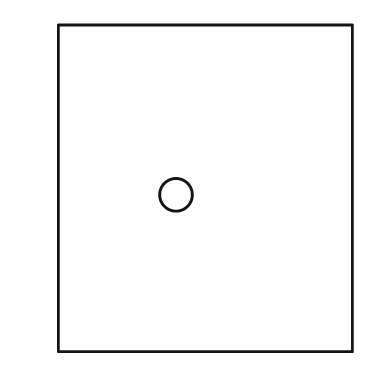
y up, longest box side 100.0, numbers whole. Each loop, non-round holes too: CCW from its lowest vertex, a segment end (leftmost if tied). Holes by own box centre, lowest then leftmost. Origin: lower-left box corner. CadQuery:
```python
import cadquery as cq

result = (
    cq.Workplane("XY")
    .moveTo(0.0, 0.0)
    .lineTo(90.0, 0.0)
    .lineTo(90.0, 100.0)
    .lineTo(0.0, 100.0)
    .close()
    .moveTo(36.0, 48.0)
    .circle(5.0)
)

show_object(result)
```